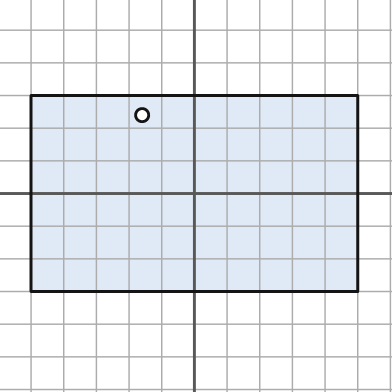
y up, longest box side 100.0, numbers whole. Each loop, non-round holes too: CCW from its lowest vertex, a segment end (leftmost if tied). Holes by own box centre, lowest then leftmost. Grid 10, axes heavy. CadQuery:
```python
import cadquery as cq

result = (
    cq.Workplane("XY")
    .moveTo(-50.0, -30.0)
    .lineTo(50.0, -30.0)
    .lineTo(50.0, 30.0)
    .lineTo(-50.0, 30.0)
    .close()
    .moveTo(-16.0, 24.0)
    .circle(2.0)
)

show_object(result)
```